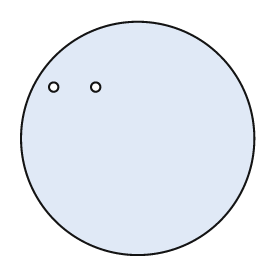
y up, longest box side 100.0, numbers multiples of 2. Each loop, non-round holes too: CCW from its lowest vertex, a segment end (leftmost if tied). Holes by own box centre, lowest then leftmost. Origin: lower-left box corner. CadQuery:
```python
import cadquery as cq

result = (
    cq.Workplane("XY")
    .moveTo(50.0, 50.0)
    .circle(50.0)
    .moveTo(14.0, 72.0)
    .circle(2.0)
    .moveTo(32.0, 72.0)
    .circle(2.0)
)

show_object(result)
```